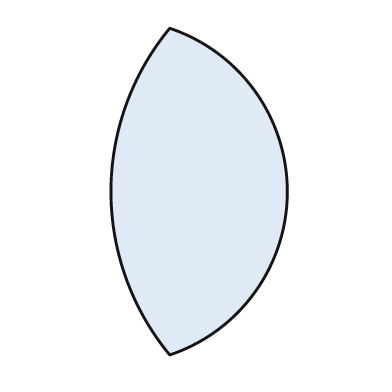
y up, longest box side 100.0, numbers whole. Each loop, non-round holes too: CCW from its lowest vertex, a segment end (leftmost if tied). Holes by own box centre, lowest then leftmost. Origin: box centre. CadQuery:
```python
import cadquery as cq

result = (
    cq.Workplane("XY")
    .moveTo(-9.0, -50.0)
    .threePointArc((27.0, 0.0), (-9.0, 50.0))
    .threePointArc((-27.0, 0.0), (-9.0, -50.0))
    .close()
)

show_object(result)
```